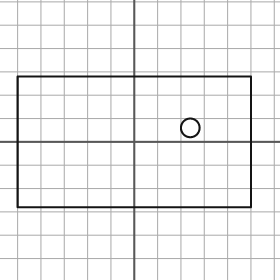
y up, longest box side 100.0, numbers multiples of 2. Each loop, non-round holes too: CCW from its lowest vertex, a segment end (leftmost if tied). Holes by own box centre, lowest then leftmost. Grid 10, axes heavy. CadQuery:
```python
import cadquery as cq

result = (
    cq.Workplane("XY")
    .moveTo(-50.0, -28.0)
    .lineTo(50.0, -28.0)
    .lineTo(50.0, 28.0)
    .lineTo(-50.0, 28.0)
    .close()
    .moveTo(24.0, 6.0)
    .circle(4.0)
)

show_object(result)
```